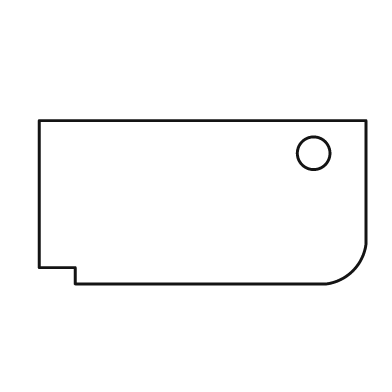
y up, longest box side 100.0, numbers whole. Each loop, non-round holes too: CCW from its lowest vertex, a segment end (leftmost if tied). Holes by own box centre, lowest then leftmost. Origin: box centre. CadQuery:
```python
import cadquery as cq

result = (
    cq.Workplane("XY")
    .moveTo(-39.0, -25.0)
    .lineTo(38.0, -25.0)
    .threePointArc((46.0, -21.0), (50.0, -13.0))
    .lineTo(50.0, 25.0)
    .lineTo(-50.0, 25.0)
    .lineTo(-50.0, -20.0)
    .lineTo(-39.0, -20.0)
    .close()
    .moveTo(34.0, 15.0)
    .circle(5.0)
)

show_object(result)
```